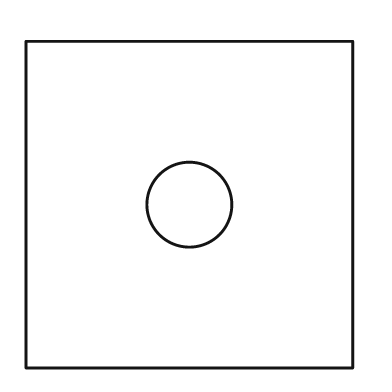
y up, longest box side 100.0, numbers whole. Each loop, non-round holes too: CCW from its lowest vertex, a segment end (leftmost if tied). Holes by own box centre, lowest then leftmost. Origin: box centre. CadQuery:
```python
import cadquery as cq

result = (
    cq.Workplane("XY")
    .moveTo(-50.0, -50.0)
    .lineTo(50.0, -50.0)
    .lineTo(50.0, 50.0)
    .lineTo(-50.0, 50.0)
    .close()
    .moveTo(0.0, 0.0)
    .circle(13.0)
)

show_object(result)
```